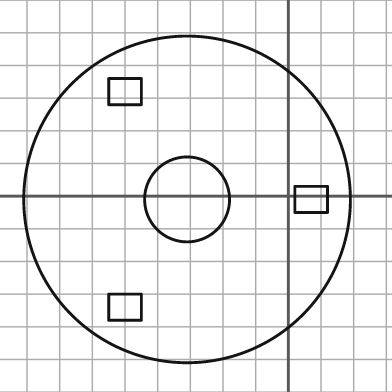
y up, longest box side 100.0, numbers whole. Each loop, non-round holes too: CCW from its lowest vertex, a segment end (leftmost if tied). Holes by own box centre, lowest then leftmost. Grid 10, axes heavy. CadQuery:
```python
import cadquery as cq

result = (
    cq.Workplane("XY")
    .moveTo(-31.0, -1.0)
    .circle(50.0)
    .moveTo(-55.0, -38.0)
    .lineTo(-45.0, -38.0)
    .lineTo(-45.0, -30.0)
    .lineTo(-55.0, -30.0)
    .close()
    .moveTo(-31.0, -1.0)
    .circle(13.0)
    .moveTo(2.0, -5.0)
    .lineTo(12.0, -5.0)
    .lineTo(12.0, 3.0)
    .lineTo(2.0, 3.0)
    .close()
    .moveTo(-55.0, 28.0)
    .lineTo(-45.0, 28.0)
    .lineTo(-45.0, 36.0)
    .lineTo(-55.0, 36.0)
    .close()
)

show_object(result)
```